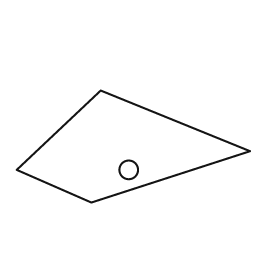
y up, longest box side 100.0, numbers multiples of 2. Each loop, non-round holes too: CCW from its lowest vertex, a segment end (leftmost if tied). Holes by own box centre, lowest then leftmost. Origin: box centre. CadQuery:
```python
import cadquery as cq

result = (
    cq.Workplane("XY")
    .moveTo(-18.0, -24.0)
    .lineTo(50.0, -2.0)
    .lineTo(-14.0, 24.0)
    .lineTo(-50.0, -10.0)
    .close()
    .moveTo(-2.0, -10.0)
    .circle(4.0)
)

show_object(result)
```